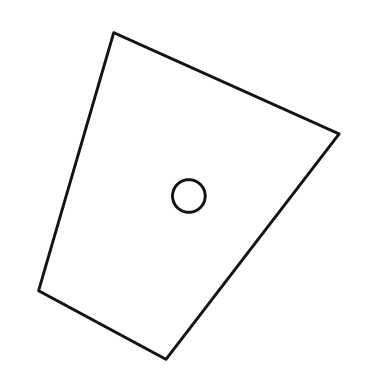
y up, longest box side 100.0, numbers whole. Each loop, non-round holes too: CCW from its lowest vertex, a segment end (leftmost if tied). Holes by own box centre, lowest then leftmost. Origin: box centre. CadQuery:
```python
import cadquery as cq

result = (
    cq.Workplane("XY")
    .moveTo(-7.0, -50.0)
    .lineTo(46.0, 19.0)
    .lineTo(-23.0, 50.0)
    .lineTo(-46.0, -29.0)
    .close()
    .moveTo(0.0, 0.0)
    .circle(5.0)
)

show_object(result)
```